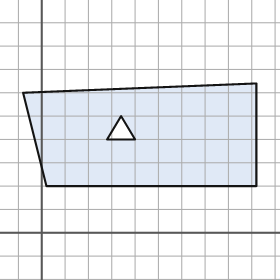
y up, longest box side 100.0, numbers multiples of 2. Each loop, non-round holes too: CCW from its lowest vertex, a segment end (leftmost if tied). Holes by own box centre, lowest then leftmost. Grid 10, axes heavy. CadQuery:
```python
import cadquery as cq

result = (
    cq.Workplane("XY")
    .moveTo(2.0, 20.0)
    .lineTo(92.0, 20.0)
    .lineTo(92.0, 64.0)
    .lineTo(-8.0, 60.0)
    .close()
    .moveTo(28.0, 40.0)
    .lineTo(40.0, 40.0)
    .lineTo(34.0, 50.0)
    .close()
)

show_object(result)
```